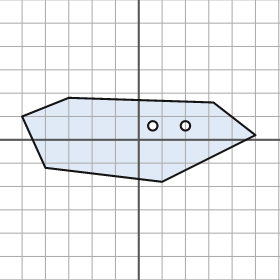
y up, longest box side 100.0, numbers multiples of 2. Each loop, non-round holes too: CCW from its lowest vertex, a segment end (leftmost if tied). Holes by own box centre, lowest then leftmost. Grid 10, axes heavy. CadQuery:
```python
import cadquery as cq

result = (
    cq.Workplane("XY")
    .moveTo(10.0, -18.0)
    .lineTo(50.0, 2.0)
    .lineTo(32.0, 16.0)
    .lineTo(-30.0, 18.0)
    .lineTo(-50.0, 10.0)
    .lineTo(-40.0, -12.0)
    .close()
    .moveTo(6.0, 6.0)
    .circle(2.0)
    .moveTo(20.0, 6.0)
    .circle(2.0)
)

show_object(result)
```